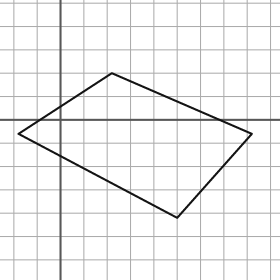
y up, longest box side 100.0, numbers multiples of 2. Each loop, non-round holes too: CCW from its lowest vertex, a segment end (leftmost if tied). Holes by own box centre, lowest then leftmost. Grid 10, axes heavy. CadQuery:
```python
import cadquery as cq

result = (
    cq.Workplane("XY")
    .moveTo(50.0, -42.0)
    .lineTo(82.0, -6.0)
    .lineTo(22.0, 20.0)
    .lineTo(-18.0, -6.0)
    .close()
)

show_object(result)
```